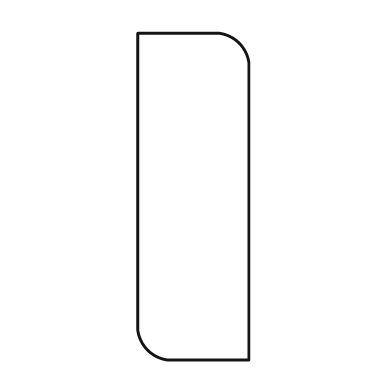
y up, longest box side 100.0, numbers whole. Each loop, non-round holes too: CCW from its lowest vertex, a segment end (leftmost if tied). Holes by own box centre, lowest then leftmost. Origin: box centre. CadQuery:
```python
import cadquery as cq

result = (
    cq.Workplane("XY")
    .moveTo(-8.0, -50.0)
    .lineTo(17.0, -50.0)
    .lineTo(17.0, 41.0)
    .threePointArc((14.0, 47.0), (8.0, 50.0))
    .lineTo(-17.0, 50.0)
    .lineTo(-17.0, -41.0)
    .threePointArc((-14.0, -47.0), (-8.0, -50.0))
    .close()
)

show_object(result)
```